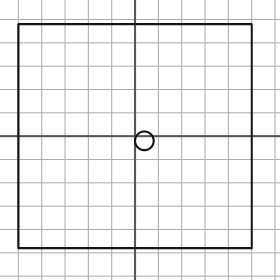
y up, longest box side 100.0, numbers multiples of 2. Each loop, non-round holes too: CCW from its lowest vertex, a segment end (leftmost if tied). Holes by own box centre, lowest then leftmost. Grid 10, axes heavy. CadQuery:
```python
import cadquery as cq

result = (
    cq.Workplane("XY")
    .moveTo(-50.0, -48.0)
    .lineTo(50.0, -48.0)
    .lineTo(50.0, 48.0)
    .lineTo(-50.0, 48.0)
    .close()
    .moveTo(4.0, -2.0)
    .circle(4.0)
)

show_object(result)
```